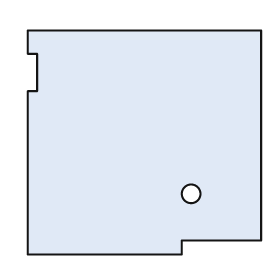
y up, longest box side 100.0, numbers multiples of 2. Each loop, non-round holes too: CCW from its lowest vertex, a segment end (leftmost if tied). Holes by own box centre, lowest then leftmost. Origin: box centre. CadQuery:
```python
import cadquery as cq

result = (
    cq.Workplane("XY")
    .moveTo(-50.0, -48.0)
    .lineTo(16.0, -48.0)
    .lineTo(16.0, -42.0)
    .lineTo(50.0, -42.0)
    .lineTo(50.0, 48.0)
    .lineTo(-50.0, 48.0)
    .lineTo(-50.0, 38.0)
    .lineTo(-46.0, 38.0)
    .lineTo(-46.0, 22.0)
    .lineTo(-50.0, 22.0)
    .close()
    .moveTo(20.0, -22.0)
    .circle(4.0)
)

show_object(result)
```